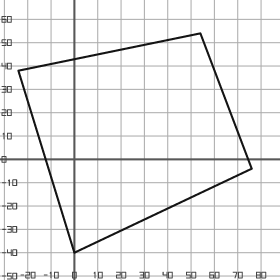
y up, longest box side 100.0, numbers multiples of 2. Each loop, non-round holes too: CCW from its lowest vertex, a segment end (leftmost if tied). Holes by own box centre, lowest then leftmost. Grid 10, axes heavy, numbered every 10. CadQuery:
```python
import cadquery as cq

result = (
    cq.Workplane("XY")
    .moveTo(0.0, -40.0)
    .lineTo(76.0, -4.0)
    .lineTo(54.0, 54.0)
    .lineTo(-24.0, 38.0)
    .close()
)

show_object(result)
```